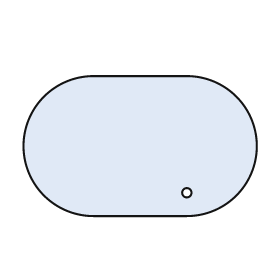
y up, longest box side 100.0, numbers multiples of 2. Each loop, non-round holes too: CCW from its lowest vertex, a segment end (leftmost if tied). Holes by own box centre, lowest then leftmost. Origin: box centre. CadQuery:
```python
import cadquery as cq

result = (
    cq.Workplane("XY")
    .moveTo(-20.0, -30.0)
    .lineTo(20.0, -30.0)
    .threePointArc((50.0, 0.0), (20.0, 30.0))
    .lineTo(-20.0, 30.0)
    .threePointArc((-50.0, 0.0), (-20.0, -30.0))
    .close()
    .moveTo(20.0, -20.0)
    .circle(2.0)
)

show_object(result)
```